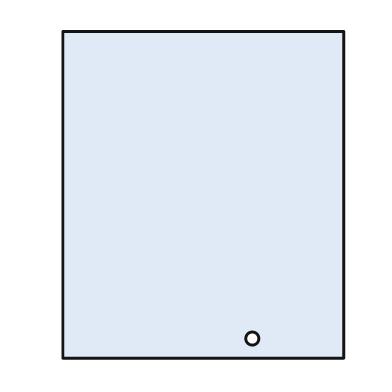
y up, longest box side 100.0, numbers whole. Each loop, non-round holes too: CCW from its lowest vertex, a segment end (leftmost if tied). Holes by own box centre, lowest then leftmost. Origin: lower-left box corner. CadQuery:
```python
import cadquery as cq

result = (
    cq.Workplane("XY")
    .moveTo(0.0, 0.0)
    .lineTo(86.0, 0.0)
    .lineTo(86.0, 100.0)
    .lineTo(0.0, 100.0)
    .close()
    .moveTo(58.0, 6.0)
    .circle(2.0)
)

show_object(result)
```